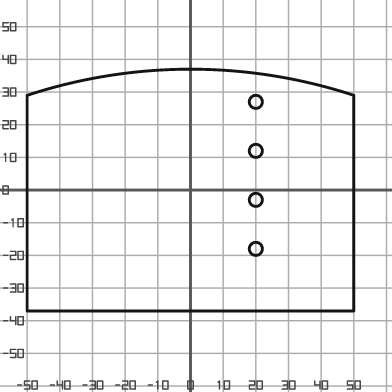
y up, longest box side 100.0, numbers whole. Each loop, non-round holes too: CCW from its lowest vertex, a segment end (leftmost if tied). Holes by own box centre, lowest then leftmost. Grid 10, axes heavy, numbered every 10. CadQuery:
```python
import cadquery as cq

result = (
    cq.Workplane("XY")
    .moveTo(-50.0, -37.0)
    .lineTo(50.0, -37.0)
    .lineTo(50.0, 29.0)
    .threePointArc((0.0, 37.0), (-50.0, 29.0))
    .close()
    .moveTo(20.0, -18.0)
    .circle(2.0)
    .moveTo(20.0, -3.0)
    .circle(2.0)
    .moveTo(20.0, 12.0)
    .circle(2.0)
    .moveTo(20.0, 27.0)
    .circle(2.0)
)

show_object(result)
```